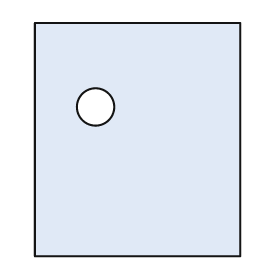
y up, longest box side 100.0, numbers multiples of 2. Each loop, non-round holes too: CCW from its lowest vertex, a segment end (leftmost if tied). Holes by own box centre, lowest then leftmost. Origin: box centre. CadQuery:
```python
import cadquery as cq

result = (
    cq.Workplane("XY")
    .moveTo(-44.0, -50.0)
    .lineTo(44.0, -50.0)
    .lineTo(44.0, 50.0)
    .lineTo(-44.0, 50.0)
    .close()
    .moveTo(-18.0, 14.0)
    .circle(8.0)
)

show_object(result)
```